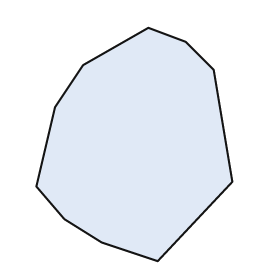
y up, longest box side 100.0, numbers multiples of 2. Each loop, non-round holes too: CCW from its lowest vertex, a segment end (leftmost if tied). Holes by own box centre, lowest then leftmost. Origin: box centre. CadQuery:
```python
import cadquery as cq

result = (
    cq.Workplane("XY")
    .moveTo(10.0, -50.0)
    .lineTo(42.0, -16.0)
    .lineTo(34.0, 32.0)
    .lineTo(22.0, 44.0)
    .lineTo(6.0, 50.0)
    .lineTo(-22.0, 34.0)
    .lineTo(-34.0, 16.0)
    .lineTo(-42.0, -18.0)
    .lineTo(-30.0, -32.0)
    .lineTo(-14.0, -42.0)
    .close()
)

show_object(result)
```